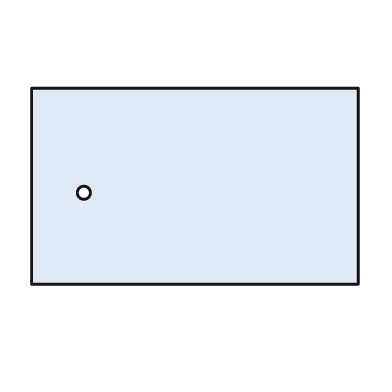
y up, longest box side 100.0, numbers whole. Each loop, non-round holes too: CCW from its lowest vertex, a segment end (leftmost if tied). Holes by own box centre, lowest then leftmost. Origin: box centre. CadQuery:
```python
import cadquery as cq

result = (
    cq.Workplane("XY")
    .moveTo(-50.0, -30.0)
    .lineTo(50.0, -30.0)
    .lineTo(50.0, 30.0)
    .lineTo(-50.0, 30.0)
    .close()
    .moveTo(-34.0, -2.0)
    .circle(2.0)
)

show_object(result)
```